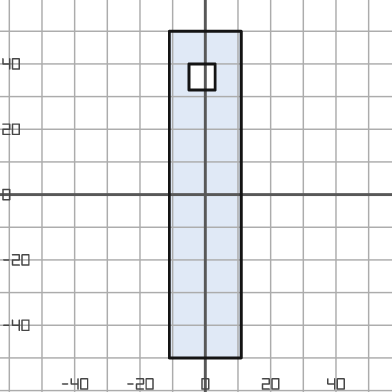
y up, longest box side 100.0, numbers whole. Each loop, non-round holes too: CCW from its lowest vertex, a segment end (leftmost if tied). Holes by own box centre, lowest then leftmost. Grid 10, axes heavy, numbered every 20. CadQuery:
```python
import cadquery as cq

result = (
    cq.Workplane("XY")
    .moveTo(-11.0, -50.0)
    .lineTo(11.0, -50.0)
    .lineTo(11.0, 50.0)
    .lineTo(-11.0, 50.0)
    .close()
    .moveTo(-5.0, 32.0)
    .lineTo(3.0, 32.0)
    .lineTo(3.0, 40.0)
    .lineTo(-5.0, 40.0)
    .close()
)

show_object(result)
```